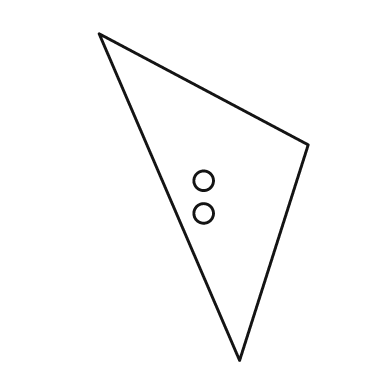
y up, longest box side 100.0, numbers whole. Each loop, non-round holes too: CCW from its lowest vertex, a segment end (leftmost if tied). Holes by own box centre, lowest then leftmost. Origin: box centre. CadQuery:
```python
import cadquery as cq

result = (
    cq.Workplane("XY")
    .moveTo(11.0, -50.0)
    .lineTo(32.0, 16.0)
    .lineTo(-32.0, 50.0)
    .close()
    .moveTo(0.0, -5.0)
    .circle(3.0)
    .moveTo(0.0, 5.0)
    .circle(3.0)
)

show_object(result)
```